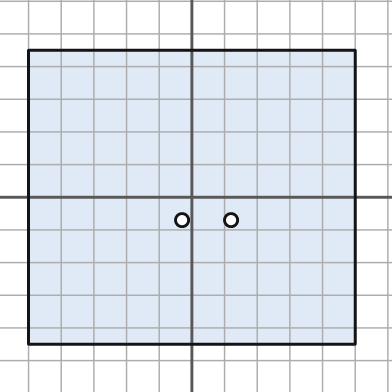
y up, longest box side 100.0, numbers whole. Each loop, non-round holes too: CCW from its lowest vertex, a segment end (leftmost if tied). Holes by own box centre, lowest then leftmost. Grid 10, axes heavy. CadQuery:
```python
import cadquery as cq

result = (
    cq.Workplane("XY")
    .moveTo(-50.0, -45.0)
    .lineTo(50.0, -45.0)
    .lineTo(50.0, 45.0)
    .lineTo(-50.0, 45.0)
    .close()
    .moveTo(-3.0, -7.0)
    .circle(2.0)
    .moveTo(12.0, -7.0)
    .circle(2.0)
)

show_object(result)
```